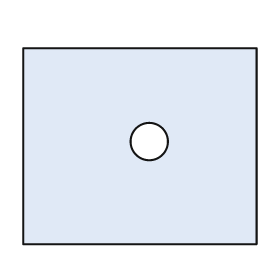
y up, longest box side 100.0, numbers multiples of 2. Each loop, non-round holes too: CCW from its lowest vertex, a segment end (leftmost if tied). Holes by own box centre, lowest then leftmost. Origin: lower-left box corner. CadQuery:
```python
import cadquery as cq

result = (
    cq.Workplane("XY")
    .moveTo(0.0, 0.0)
    .lineTo(100.0, 0.0)
    .lineTo(100.0, 84.0)
    .lineTo(0.0, 84.0)
    .close()
    .moveTo(54.0, 44.0)
    .circle(8.0)
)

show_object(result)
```